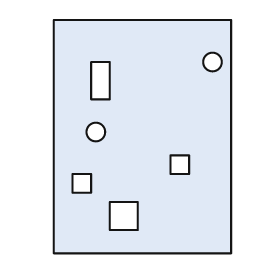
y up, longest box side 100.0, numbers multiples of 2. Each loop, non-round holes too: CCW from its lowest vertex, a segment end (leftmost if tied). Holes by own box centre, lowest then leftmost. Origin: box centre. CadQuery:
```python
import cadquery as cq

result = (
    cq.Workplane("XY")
    .moveTo(-38.0, -50.0)
    .lineTo(38.0, -50.0)
    .lineTo(38.0, 50.0)
    .lineTo(-38.0, 50.0)
    .close()
    .moveTo(-14.0, -40.0)
    .lineTo(-2.0, -40.0)
    .lineTo(-2.0, -28.0)
    .lineTo(-14.0, -28.0)
    .close()
    .moveTo(-30.0, -24.0)
    .lineTo(-22.0, -24.0)
    .lineTo(-22.0, -16.0)
    .lineTo(-30.0, -16.0)
    .close()
    .moveTo(12.0, -16.0)
    .lineTo(20.0, -16.0)
    .lineTo(20.0, -8.0)
    .lineTo(12.0, -8.0)
    .close()
    .moveTo(-20.0, 2.0)
    .circle(4.0)
    .moveTo(-22.0, 16.0)
    .lineTo(-14.0, 16.0)
    .lineTo(-14.0, 32.0)
    .lineTo(-22.0, 32.0)
    .close()
    .moveTo(30.0, 32.0)
    .circle(4.0)
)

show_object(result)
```